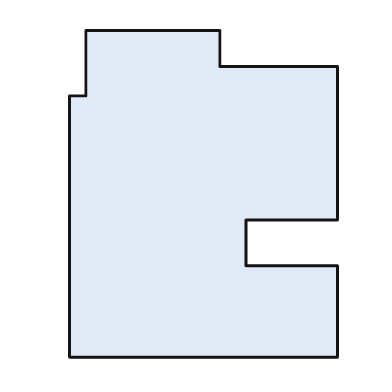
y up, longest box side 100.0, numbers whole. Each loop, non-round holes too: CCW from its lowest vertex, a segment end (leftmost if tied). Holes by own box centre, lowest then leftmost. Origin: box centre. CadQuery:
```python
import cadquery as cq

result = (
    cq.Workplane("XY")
    .moveTo(-41.0, -50.0)
    .lineTo(41.0, -50.0)
    .lineTo(41.0, -22.0)
    .lineTo(13.0, -22.0)
    .lineTo(13.0, -8.0)
    .lineTo(41.0, -8.0)
    .lineTo(41.0, 39.0)
    .lineTo(5.0, 39.0)
    .lineTo(5.0, 50.0)
    .lineTo(-36.0, 50.0)
    .lineTo(-36.0, 30.0)
    .lineTo(-41.0, 30.0)
    .close()
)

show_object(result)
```